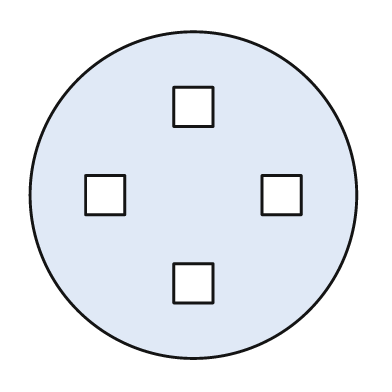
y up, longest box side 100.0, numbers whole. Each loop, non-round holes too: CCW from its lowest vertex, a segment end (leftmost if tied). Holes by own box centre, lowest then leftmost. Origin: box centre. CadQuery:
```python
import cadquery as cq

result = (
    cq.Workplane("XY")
    .moveTo(0.0, 0.0)
    .circle(50.0)
    .moveTo(-6.0, -33.0)
    .lineTo(6.0, -33.0)
    .lineTo(6.0, -21.0)
    .lineTo(-6.0, -21.0)
    .close()
    .moveTo(-33.0, -6.0)
    .lineTo(-21.0, -6.0)
    .lineTo(-21.0, 6.0)
    .lineTo(-33.0, 6.0)
    .close()
    .moveTo(21.0, -6.0)
    .lineTo(33.0, -6.0)
    .lineTo(33.0, 6.0)
    .lineTo(21.0, 6.0)
    .close()
    .moveTo(-6.0, 21.0)
    .lineTo(6.0, 21.0)
    .lineTo(6.0, 33.0)
    .lineTo(-6.0, 33.0)
    .close()
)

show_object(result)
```